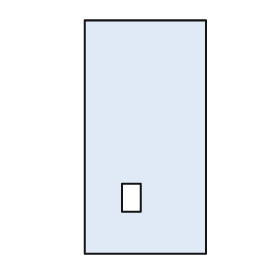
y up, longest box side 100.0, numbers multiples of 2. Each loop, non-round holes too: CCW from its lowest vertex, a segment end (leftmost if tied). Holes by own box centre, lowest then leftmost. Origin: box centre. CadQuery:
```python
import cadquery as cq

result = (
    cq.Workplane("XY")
    .moveTo(-26.0, -50.0)
    .lineTo(26.0, -50.0)
    .lineTo(26.0, 50.0)
    .lineTo(-26.0, 50.0)
    .close()
    .moveTo(-10.0, -32.0)
    .lineTo(-2.0, -32.0)
    .lineTo(-2.0, -20.0)
    .lineTo(-10.0, -20.0)
    .close()
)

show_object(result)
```